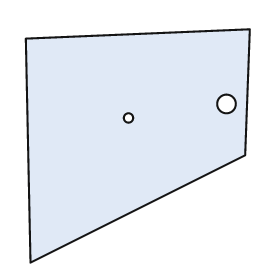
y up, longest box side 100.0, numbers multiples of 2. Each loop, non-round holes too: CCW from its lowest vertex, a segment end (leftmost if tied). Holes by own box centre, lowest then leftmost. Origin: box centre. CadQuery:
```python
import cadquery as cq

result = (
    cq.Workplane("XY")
    .moveTo(-46.0, -50.0)
    .lineTo(46.0, -4.0)
    .lineTo(48.0, 50.0)
    .lineTo(-48.0, 46.0)
    .close()
    .moveTo(-4.0, 12.0)
    .circle(2.0)
    .moveTo(38.0, 18.0)
    .circle(4.0)
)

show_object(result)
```